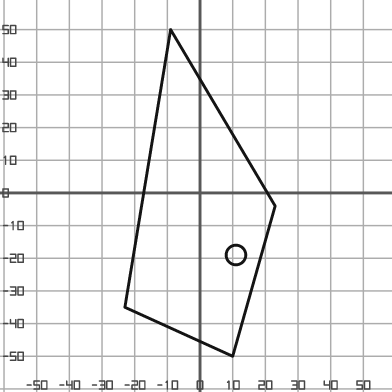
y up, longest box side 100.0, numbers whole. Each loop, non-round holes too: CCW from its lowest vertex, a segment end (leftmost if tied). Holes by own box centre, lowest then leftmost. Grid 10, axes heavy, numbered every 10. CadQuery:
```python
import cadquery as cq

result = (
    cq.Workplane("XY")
    .moveTo(10.0, -50.0)
    .lineTo(23.0, -4.0)
    .lineTo(-9.0, 50.0)
    .lineTo(-23.0, -35.0)
    .close()
    .moveTo(11.0, -19.0)
    .circle(3.0)
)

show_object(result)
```